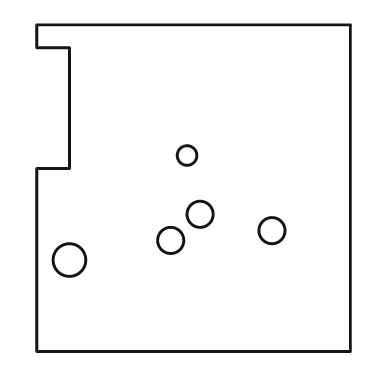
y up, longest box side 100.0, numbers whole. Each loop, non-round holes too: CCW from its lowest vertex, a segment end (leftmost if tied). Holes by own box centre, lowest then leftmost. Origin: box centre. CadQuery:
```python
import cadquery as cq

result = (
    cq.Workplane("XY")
    .moveTo(-48.0, -50.0)
    .lineTo(48.0, -50.0)
    .lineTo(48.0, 50.0)
    .lineTo(-48.0, 50.0)
    .lineTo(-48.0, 43.0)
    .lineTo(-38.0, 43.0)
    .lineTo(-38.0, 6.0)
    .lineTo(-48.0, 6.0)
    .close()
    .moveTo(-38.0, -22.0)
    .circle(5.0)
    .moveTo(-7.0, -16.0)
    .circle(4.0)
    .moveTo(24.0, -13.0)
    .circle(4.0)
    .moveTo(2.0, -8.0)
    .circle(4.0)
    .moveTo(-2.0, 10.0)
    .circle(3.0)
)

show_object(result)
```